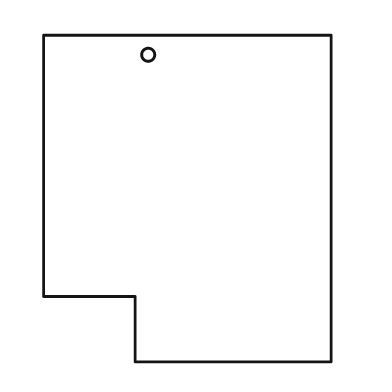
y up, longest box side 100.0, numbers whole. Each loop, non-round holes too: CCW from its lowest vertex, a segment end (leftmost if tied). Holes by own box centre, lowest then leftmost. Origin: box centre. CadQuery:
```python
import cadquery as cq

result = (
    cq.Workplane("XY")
    .moveTo(-16.0, -50.0)
    .lineTo(44.0, -50.0)
    .lineTo(44.0, 50.0)
    .lineTo(-44.0, 50.0)
    .lineTo(-44.0, -30.0)
    .lineTo(-16.0, -30.0)
    .close()
    .moveTo(-12.0, 44.0)
    .circle(2.0)
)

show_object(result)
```